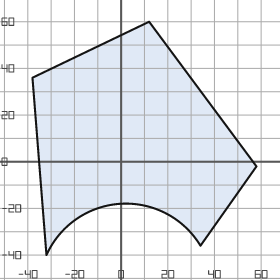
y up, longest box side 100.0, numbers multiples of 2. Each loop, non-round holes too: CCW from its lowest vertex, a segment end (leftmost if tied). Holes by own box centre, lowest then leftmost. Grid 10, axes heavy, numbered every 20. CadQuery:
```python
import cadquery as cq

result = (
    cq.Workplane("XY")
    .moveTo(-32.0, -40.0)
    .threePointArc((0.0, -18.0), (34.0, -36.0))
    .lineTo(58.0, -2.0)
    .lineTo(12.0, 60.0)
    .lineTo(-38.0, 36.0)
    .close()
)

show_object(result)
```